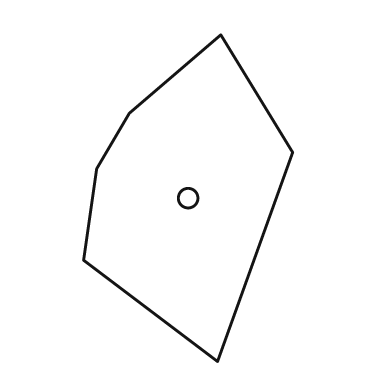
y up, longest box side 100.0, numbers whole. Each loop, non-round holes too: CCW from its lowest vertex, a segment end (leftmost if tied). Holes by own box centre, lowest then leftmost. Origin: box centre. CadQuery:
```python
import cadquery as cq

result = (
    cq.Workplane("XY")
    .moveTo(9.0, -50.0)
    .lineTo(32.0, 14.0)
    .lineTo(10.0, 50.0)
    .lineTo(-18.0, 26.0)
    .lineTo(-28.0, 9.0)
    .lineTo(-32.0, -19.0)
    .close()
    .moveTo(0.0, 0.0)
    .circle(3.0)
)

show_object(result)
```